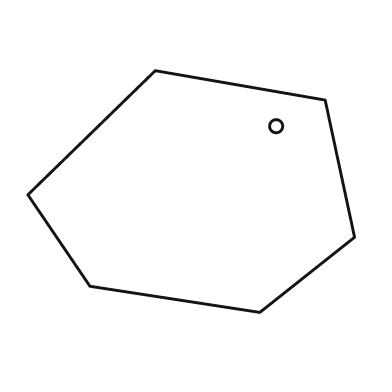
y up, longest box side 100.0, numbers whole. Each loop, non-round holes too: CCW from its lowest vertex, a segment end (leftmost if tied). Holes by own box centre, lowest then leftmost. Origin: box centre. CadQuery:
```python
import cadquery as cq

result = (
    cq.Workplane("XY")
    .moveTo(21.0, -37.0)
    .lineTo(50.0, -14.0)
    .lineTo(41.0, 28.0)
    .lineTo(-11.0, 37.0)
    .lineTo(-50.0, -1.0)
    .lineTo(-31.0, -29.0)
    .close()
    .moveTo(26.0, 20.0)
    .circle(2.0)
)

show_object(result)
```